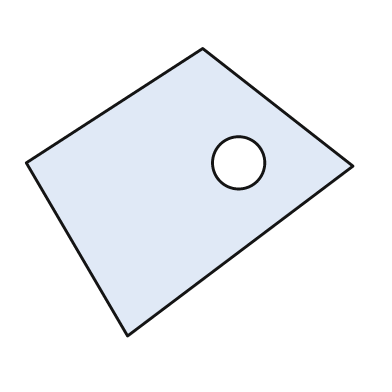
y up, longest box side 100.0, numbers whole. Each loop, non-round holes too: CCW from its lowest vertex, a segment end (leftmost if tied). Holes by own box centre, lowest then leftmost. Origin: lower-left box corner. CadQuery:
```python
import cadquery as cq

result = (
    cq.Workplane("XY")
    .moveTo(31.0, 0.0)
    .lineTo(100.0, 52.0)
    .lineTo(54.0, 88.0)
    .lineTo(0.0, 53.0)
    .close()
    .moveTo(65.0, 53.0)
    .circle(8.0)
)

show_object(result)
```